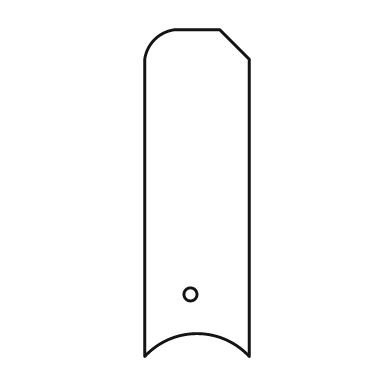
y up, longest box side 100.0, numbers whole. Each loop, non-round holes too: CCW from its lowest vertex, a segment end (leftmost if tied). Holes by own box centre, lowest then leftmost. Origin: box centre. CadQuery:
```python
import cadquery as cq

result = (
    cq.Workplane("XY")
    .moveTo(-16.0, -50.0)
    .threePointArc((0.0, -43.0), (16.0, -50.0))
    .lineTo(16.0, 41.0)
    .lineTo(7.0, 50.0)
    .lineTo(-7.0, 50.0)
    .threePointArc((-13.0, 47.0), (-16.0, 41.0))
    .close()
    .moveTo(-2.0, -31.0)
    .circle(2.0)
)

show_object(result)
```